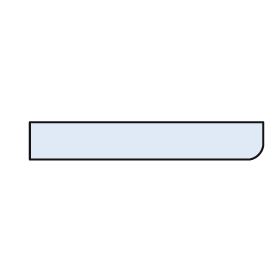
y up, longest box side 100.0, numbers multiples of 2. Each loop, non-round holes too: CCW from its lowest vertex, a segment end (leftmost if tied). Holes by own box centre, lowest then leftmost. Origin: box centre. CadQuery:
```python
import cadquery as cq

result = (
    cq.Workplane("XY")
    .moveTo(-50.0, -8.0)
    .lineTo(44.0, -8.0)
    .threePointArc((48.0, -6.0), (50.0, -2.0))
    .lineTo(50.0, 8.0)
    .lineTo(-50.0, 8.0)
    .close()
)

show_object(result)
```